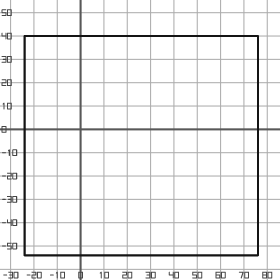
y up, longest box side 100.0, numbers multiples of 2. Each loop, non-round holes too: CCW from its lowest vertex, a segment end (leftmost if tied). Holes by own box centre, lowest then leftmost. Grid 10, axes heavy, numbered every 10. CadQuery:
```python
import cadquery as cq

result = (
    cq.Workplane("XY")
    .moveTo(-24.0, -54.0)
    .lineTo(76.0, -54.0)
    .lineTo(76.0, 40.0)
    .lineTo(-24.0, 40.0)
    .close()
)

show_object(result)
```